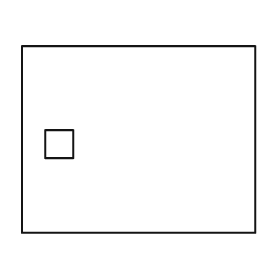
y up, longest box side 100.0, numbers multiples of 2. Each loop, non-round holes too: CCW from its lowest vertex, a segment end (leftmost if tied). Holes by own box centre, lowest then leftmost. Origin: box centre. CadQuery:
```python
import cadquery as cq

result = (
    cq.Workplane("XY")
    .moveTo(-50.0, -40.0)
    .lineTo(50.0, -40.0)
    .lineTo(50.0, 40.0)
    .lineTo(-50.0, 40.0)
    .close()
    .moveTo(-40.0, -8.0)
    .lineTo(-28.0, -8.0)
    .lineTo(-28.0, 4.0)
    .lineTo(-40.0, 4.0)
    .close()
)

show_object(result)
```